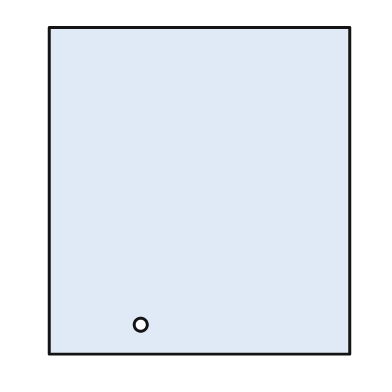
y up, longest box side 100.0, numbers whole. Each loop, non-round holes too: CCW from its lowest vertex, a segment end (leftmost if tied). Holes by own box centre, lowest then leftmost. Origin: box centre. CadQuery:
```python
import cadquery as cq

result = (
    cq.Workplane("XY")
    .moveTo(-46.0, -50.0)
    .lineTo(46.0, -50.0)
    .lineTo(46.0, 50.0)
    .lineTo(-46.0, 50.0)
    .close()
    .moveTo(-18.0, -41.0)
    .circle(2.0)
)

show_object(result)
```